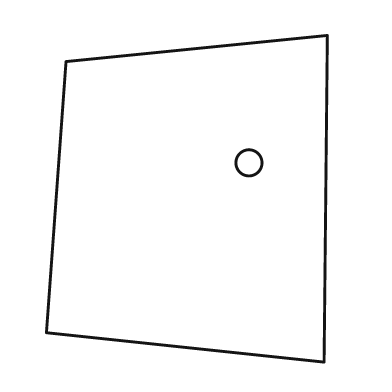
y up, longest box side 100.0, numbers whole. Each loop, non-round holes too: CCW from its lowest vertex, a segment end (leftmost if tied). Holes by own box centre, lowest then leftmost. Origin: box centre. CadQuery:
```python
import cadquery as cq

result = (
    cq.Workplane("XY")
    .moveTo(42.0, -50.0)
    .lineTo(43.0, 50.0)
    .lineTo(-37.0, 42.0)
    .lineTo(-43.0, -41.0)
    .close()
    .moveTo(19.0, 11.0)
    .circle(4.0)
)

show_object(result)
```